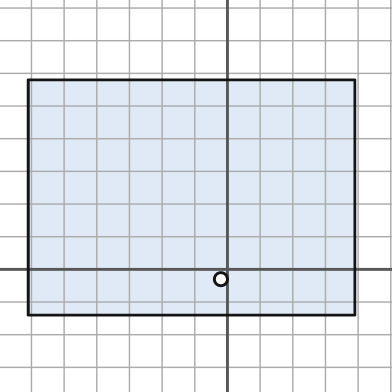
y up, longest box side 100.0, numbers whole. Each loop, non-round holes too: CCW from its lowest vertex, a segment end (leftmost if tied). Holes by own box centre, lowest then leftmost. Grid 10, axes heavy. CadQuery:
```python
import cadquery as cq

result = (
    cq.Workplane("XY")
    .moveTo(-61.0, -14.0)
    .lineTo(39.0, -14.0)
    .lineTo(39.0, 58.0)
    .lineTo(-61.0, 58.0)
    .close()
    .moveTo(-2.0, -3.0)
    .circle(2.0)
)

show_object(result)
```